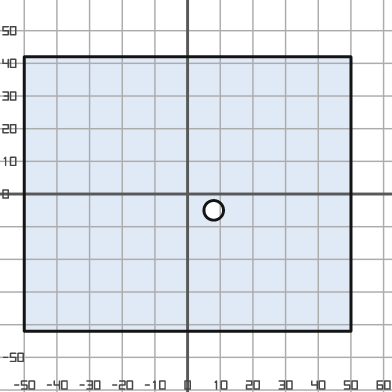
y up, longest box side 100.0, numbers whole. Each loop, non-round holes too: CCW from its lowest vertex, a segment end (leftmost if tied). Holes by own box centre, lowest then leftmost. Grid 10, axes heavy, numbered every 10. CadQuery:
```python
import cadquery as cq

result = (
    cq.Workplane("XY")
    .moveTo(-50.0, -42.0)
    .lineTo(50.0, -42.0)
    .lineTo(50.0, 42.0)
    .lineTo(-50.0, 42.0)
    .close()
    .moveTo(8.0, -5.0)
    .circle(3.0)
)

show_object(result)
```